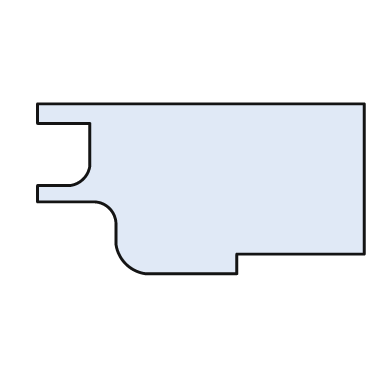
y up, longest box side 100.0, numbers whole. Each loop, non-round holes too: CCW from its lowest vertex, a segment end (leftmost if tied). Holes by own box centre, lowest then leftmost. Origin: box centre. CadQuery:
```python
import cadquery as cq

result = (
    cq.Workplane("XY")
    .moveTo(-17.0, -26.0)
    .lineTo(11.0, -26.0)
    .lineTo(11.0, -20.0)
    .lineTo(50.0, -20.0)
    .lineTo(50.0, 26.0)
    .lineTo(-50.0, 26.0)
    .lineTo(-50.0, 20.0)
    .lineTo(-34.0, 20.0)
    .lineTo(-34.0, 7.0)
    .threePointArc((-36.0, 3.0), (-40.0, 1.0))
    .lineTo(-50.0, 1.0)
    .lineTo(-50.0, -4.0)
    .lineTo(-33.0, -4.0)
    .threePointArc((-28.0, -6.0), (-26.0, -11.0))
    .lineTo(-26.0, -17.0)
    .threePointArc((-23.0, -23.0), (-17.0, -26.0))
    .close()
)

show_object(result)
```